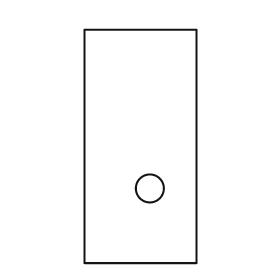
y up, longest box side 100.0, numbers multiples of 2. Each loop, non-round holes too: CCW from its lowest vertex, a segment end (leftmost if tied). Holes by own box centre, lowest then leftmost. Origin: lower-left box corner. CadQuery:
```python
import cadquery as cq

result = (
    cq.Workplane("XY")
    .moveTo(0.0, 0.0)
    .lineTo(48.0, 0.0)
    .lineTo(48.0, 100.0)
    .lineTo(0.0, 100.0)
    .close()
    .moveTo(28.0, 32.0)
    .circle(6.0)
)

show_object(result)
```